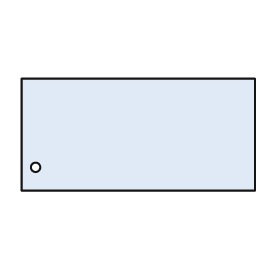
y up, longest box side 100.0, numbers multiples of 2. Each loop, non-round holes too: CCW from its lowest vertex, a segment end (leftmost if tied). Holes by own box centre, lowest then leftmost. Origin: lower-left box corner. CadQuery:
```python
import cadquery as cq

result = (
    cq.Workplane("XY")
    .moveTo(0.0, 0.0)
    .lineTo(100.0, 0.0)
    .lineTo(100.0, 48.0)
    .lineTo(0.0, 48.0)
    .close()
    .moveTo(6.0, 10.0)
    .circle(2.0)
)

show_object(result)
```